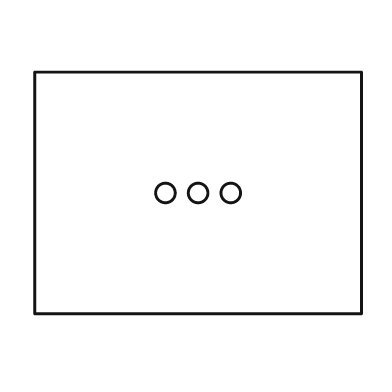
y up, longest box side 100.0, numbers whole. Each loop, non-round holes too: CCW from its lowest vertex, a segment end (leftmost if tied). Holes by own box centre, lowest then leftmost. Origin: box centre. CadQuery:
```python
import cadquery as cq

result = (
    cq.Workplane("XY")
    .moveTo(-50.0, -37.0)
    .lineTo(50.0, -37.0)
    .lineTo(50.0, 37.0)
    .lineTo(-50.0, 37.0)
    .close()
    .moveTo(-10.0, 0.0)
    .circle(3.0)
    .moveTo(0.0, 0.0)
    .circle(3.0)
    .moveTo(10.0, 0.0)
    .circle(3.0)
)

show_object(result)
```